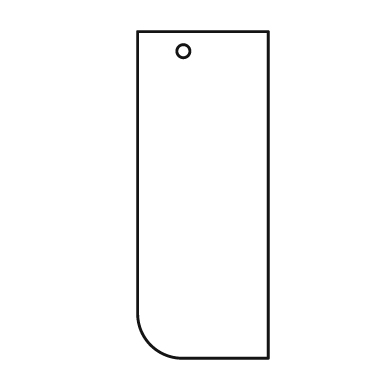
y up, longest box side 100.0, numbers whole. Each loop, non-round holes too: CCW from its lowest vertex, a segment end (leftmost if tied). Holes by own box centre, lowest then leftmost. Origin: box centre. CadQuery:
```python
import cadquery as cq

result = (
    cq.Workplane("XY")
    .moveTo(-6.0, -50.0)
    .lineTo(20.0, -50.0)
    .lineTo(20.0, 50.0)
    .lineTo(-20.0, 50.0)
    .lineTo(-20.0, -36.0)
    .threePointArc((-16.0, -46.0), (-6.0, -50.0))
    .close()
    .moveTo(-6.0, 44.0)
    .circle(2.0)
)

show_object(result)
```